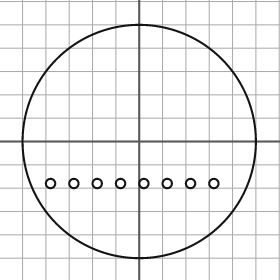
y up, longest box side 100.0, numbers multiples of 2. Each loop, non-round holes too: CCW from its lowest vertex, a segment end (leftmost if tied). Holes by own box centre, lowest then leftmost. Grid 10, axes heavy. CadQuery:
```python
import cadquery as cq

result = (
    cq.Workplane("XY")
    .moveTo(0.0, 0.0)
    .circle(50.0)
    .moveTo(-38.0, -18.0)
    .circle(2.0)
    .moveTo(-28.0, -18.0)
    .circle(2.0)
    .moveTo(-18.0, -18.0)
    .circle(2.0)
    .moveTo(-8.0, -18.0)
    .circle(2.0)
    .moveTo(2.0, -18.0)
    .circle(2.0)
    .moveTo(12.0, -18.0)
    .circle(2.0)
    .moveTo(22.0, -18.0)
    .circle(2.0)
    .moveTo(32.0, -18.0)
    .circle(2.0)
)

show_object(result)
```